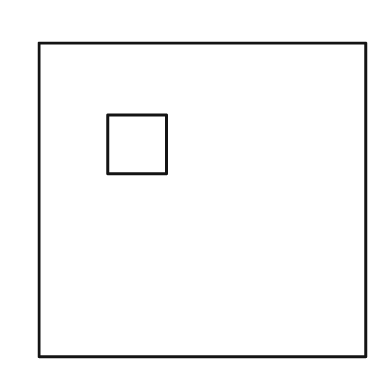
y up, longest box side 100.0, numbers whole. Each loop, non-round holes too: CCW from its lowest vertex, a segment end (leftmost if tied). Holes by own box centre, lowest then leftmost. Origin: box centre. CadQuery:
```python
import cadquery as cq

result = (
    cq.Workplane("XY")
    .moveTo(-50.0, -48.0)
    .lineTo(50.0, -48.0)
    .lineTo(50.0, 48.0)
    .lineTo(-50.0, 48.0)
    .close()
    .moveTo(-29.0, 8.0)
    .lineTo(-11.0, 8.0)
    .lineTo(-11.0, 26.0)
    .lineTo(-29.0, 26.0)
    .close()
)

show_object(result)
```